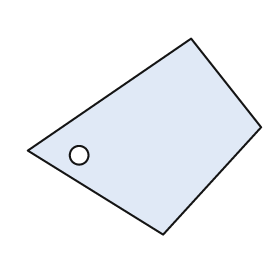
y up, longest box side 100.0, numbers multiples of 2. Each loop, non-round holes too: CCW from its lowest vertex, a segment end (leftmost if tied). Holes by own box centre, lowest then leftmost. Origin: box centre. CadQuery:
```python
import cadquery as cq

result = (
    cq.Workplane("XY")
    .moveTo(8.0, -42.0)
    .lineTo(50.0, 4.0)
    .lineTo(20.0, 42.0)
    .lineTo(-50.0, -6.0)
    .close()
    .moveTo(-28.0, -8.0)
    .circle(4.0)
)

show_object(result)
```